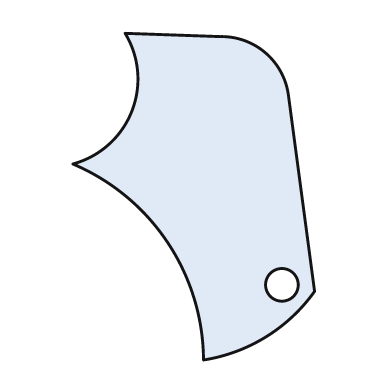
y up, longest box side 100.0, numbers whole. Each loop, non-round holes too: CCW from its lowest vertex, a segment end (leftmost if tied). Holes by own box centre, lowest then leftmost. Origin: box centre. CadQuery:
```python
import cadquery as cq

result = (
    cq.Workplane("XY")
    .moveTo(3.0, -50.0)
    .threePointArc((22.0, -43.0), (37.0, -29.0))
    .lineTo(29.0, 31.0)
    .threePointArc((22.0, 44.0), (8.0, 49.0))
    .lineTo(-21.0, 50.0)
    .threePointArc((-19.0, 26.0), (-37.0, 10.0))
    .threePointArc((-8.0, -14.0), (3.0, -50.0))
    .close()
    .moveTo(27.0, -27.0)
    .circle(5.0)
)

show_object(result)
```